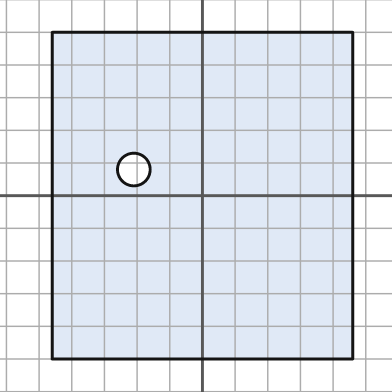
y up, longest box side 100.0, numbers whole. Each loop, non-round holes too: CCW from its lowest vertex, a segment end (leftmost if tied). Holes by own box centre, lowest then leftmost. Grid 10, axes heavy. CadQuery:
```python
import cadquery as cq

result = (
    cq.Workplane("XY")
    .moveTo(-46.0, -50.0)
    .lineTo(46.0, -50.0)
    .lineTo(46.0, 50.0)
    .lineTo(-46.0, 50.0)
    .close()
    .moveTo(-21.0, 8.0)
    .circle(5.0)
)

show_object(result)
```